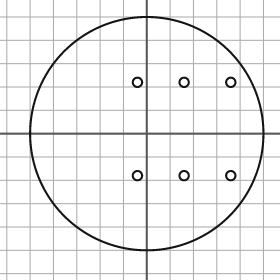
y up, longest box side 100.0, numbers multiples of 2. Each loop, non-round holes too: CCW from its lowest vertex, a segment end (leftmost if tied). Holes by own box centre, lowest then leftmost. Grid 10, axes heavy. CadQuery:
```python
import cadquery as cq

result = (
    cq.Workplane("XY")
    .moveTo(0.0, 0.0)
    .circle(50.0)
    .moveTo(-4.0, -18.0)
    .circle(2.0)
    .moveTo(16.0, -18.0)
    .circle(2.0)
    .moveTo(36.0, -18.0)
    .circle(2.0)
    .moveTo(-4.0, 22.0)
    .circle(2.0)
    .moveTo(16.0, 22.0)
    .circle(2.0)
    .moveTo(36.0, 22.0)
    .circle(2.0)
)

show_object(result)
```